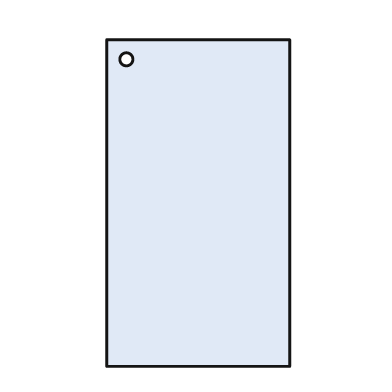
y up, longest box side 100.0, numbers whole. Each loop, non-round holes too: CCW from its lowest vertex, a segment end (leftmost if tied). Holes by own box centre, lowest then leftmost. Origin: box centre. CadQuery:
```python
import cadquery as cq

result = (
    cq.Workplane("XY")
    .moveTo(-28.0, -50.0)
    .lineTo(28.0, -50.0)
    .lineTo(28.0, 50.0)
    .lineTo(-28.0, 50.0)
    .close()
    .moveTo(-22.0, 44.0)
    .circle(2.0)
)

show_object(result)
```